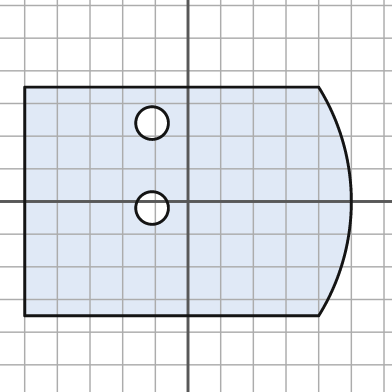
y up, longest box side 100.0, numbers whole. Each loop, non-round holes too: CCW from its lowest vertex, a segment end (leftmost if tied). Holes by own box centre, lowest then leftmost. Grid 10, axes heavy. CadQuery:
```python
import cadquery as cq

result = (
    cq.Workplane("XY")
    .moveTo(-50.0, -35.0)
    .lineTo(40.0, -35.0)
    .threePointArc((50.0, 0.0), (40.0, 35.0))
    .lineTo(-50.0, 35.0)
    .close()
    .moveTo(-11.0, -2.0)
    .circle(5.0)
    .moveTo(-11.0, 24.0)
    .circle(5.0)
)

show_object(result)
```